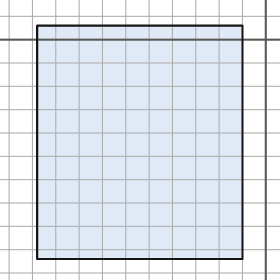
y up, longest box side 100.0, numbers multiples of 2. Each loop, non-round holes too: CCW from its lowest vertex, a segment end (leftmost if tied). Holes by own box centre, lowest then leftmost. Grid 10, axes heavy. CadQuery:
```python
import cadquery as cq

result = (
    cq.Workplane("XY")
    .moveTo(-98.0, -94.0)
    .lineTo(-10.0, -94.0)
    .lineTo(-10.0, 6.0)
    .lineTo(-98.0, 6.0)
    .close()
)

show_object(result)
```